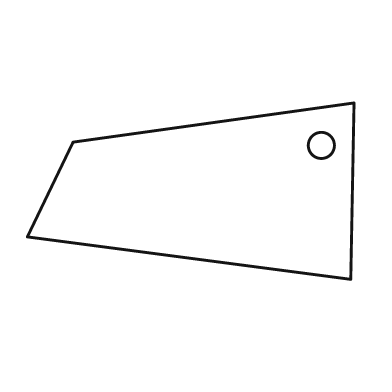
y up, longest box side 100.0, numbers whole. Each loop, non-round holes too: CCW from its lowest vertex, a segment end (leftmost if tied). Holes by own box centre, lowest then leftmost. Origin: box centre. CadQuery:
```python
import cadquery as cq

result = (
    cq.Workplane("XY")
    .moveTo(49.0, -27.0)
    .lineTo(50.0, 27.0)
    .lineTo(-36.0, 15.0)
    .lineTo(-50.0, -14.0)
    .close()
    .moveTo(40.0, 14.0)
    .circle(4.0)
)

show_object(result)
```